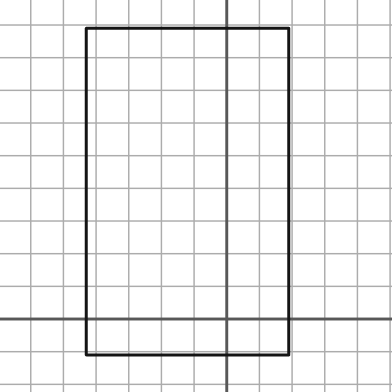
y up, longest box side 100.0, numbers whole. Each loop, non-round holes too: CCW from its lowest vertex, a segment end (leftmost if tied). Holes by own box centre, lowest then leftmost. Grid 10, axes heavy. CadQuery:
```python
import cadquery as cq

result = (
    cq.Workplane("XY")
    .moveTo(-43.0, -11.0)
    .lineTo(19.0, -11.0)
    .lineTo(19.0, 89.0)
    .lineTo(-43.0, 89.0)
    .close()
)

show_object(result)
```